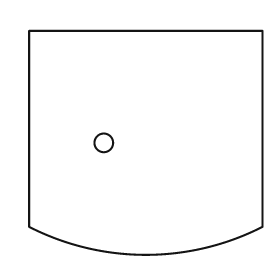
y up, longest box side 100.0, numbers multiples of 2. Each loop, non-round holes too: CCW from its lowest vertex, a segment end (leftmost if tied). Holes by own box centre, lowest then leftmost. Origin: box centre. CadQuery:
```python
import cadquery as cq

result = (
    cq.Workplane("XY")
    .moveTo(-50.0, -36.0)
    .threePointArc((0.0, -48.0), (50.0, -36.0))
    .lineTo(50.0, 48.0)
    .lineTo(-50.0, 48.0)
    .close()
    .moveTo(-18.0, 0.0)
    .circle(4.0)
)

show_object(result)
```